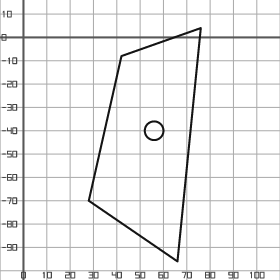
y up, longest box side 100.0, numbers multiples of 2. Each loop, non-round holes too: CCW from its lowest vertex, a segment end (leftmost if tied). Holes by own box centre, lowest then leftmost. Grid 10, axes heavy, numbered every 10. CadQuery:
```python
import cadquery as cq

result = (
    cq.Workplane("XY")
    .moveTo(66.0, -96.0)
    .lineTo(76.0, 4.0)
    .lineTo(42.0, -8.0)
    .lineTo(28.0, -70.0)
    .close()
    .moveTo(56.0, -40.0)
    .circle(4.0)
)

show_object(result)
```